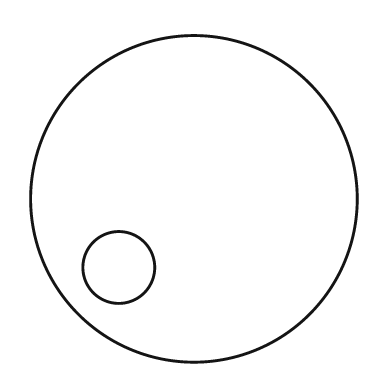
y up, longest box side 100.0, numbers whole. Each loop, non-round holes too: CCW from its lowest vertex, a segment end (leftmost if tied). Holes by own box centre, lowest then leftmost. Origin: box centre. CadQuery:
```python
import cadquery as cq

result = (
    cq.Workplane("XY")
    .moveTo(0.0, 0.0)
    .circle(50.0)
    .moveTo(-23.0, -21.0)
    .circle(11.0)
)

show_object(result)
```